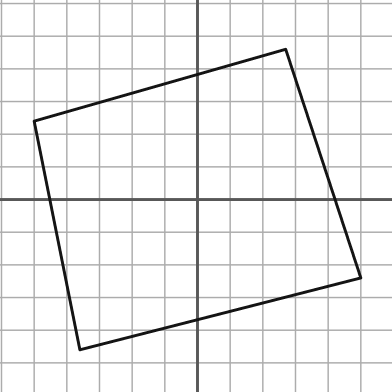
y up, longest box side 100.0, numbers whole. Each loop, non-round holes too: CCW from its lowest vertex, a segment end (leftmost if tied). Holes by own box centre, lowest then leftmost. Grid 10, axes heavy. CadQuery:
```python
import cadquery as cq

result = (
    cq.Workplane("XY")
    .moveTo(-36.0, -46.0)
    .lineTo(50.0, -24.0)
    .lineTo(27.0, 46.0)
    .lineTo(-50.0, 24.0)
    .close()
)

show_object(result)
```